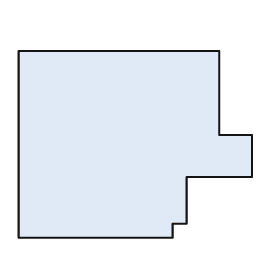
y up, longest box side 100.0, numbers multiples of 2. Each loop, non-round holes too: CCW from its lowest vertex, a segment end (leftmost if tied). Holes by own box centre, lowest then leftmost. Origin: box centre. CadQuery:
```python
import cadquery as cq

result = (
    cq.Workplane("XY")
    .moveTo(-50.0, -40.0)
    .lineTo(16.0, -40.0)
    .lineTo(16.0, -34.0)
    .lineTo(22.0, -34.0)
    .lineTo(22.0, -14.0)
    .lineTo(50.0, -14.0)
    .lineTo(50.0, 4.0)
    .lineTo(36.0, 4.0)
    .lineTo(36.0, 40.0)
    .lineTo(-50.0, 40.0)
    .close()
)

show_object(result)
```